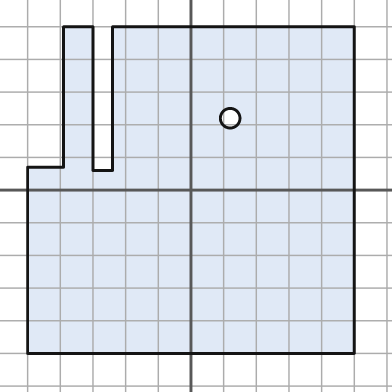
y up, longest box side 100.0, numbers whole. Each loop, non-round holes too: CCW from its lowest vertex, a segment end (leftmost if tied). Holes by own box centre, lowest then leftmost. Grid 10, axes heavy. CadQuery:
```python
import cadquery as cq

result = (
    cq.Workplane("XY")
    .moveTo(-50.0, -50.0)
    .lineTo(50.0, -50.0)
    .lineTo(50.0, 50.0)
    .lineTo(-24.0, 50.0)
    .lineTo(-24.0, 6.0)
    .lineTo(-30.0, 6.0)
    .lineTo(-30.0, 50.0)
    .lineTo(-39.0, 50.0)
    .lineTo(-39.0, 7.0)
    .lineTo(-50.0, 7.0)
    .close()
    .moveTo(12.0, 22.0)
    .circle(3.0)
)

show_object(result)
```